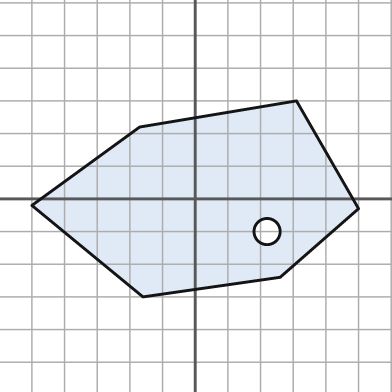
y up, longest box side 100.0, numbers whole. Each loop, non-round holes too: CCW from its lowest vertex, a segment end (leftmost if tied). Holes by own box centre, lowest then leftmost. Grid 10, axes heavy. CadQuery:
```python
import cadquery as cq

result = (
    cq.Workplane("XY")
    .moveTo(-16.0, -30.0)
    .lineTo(26.0, -24.0)
    .lineTo(50.0, -3.0)
    .lineTo(31.0, 30.0)
    .lineTo(-17.0, 22.0)
    .lineTo(-50.0, -2.0)
    .close()
    .moveTo(22.0, -10.0)
    .circle(4.0)
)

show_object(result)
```